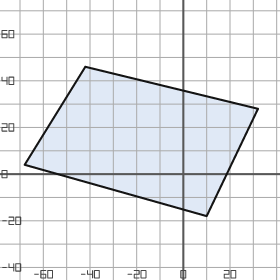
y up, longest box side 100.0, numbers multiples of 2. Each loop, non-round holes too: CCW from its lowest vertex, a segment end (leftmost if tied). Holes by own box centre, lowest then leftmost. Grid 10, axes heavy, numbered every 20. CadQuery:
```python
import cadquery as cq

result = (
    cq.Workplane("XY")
    .moveTo(10.0, -18.0)
    .lineTo(32.0, 28.0)
    .lineTo(-42.0, 46.0)
    .lineTo(-68.0, 4.0)
    .close()
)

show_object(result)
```